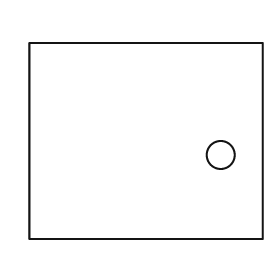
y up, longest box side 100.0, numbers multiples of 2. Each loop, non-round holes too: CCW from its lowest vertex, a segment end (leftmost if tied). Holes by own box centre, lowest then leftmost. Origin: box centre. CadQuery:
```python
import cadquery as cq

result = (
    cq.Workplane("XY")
    .moveTo(-50.0, -42.0)
    .lineTo(50.0, -42.0)
    .lineTo(50.0, 42.0)
    .lineTo(-50.0, 42.0)
    .close()
    .moveTo(32.0, -6.0)
    .circle(6.0)
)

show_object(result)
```